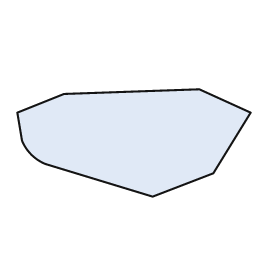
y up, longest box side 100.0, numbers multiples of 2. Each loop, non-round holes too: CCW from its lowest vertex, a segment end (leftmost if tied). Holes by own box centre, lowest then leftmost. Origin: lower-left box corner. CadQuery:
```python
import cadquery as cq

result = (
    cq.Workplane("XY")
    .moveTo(58.0, 0.0)
    .lineTo(84.0, 10.0)
    .lineTo(100.0, 36.0)
    .lineTo(78.0, 46.0)
    .lineTo(20.0, 44.0)
    .lineTo(0.0, 36.0)
    .lineTo(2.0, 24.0)
    .threePointArc((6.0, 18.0), (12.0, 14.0))
    .close()
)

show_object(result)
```